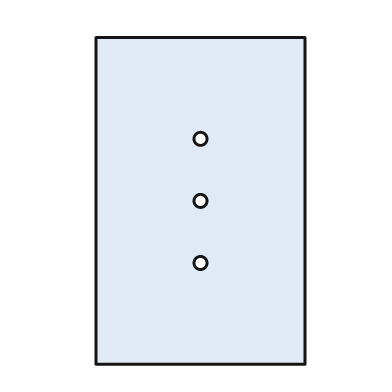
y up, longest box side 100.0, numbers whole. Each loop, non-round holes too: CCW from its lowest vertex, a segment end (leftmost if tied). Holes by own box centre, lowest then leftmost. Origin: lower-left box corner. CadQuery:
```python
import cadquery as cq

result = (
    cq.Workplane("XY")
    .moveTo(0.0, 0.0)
    .lineTo(64.0, 0.0)
    .lineTo(64.0, 100.0)
    .lineTo(0.0, 100.0)
    .close()
    .moveTo(32.0, 31.0)
    .circle(2.0)
    .moveTo(32.0, 50.0)
    .circle(2.0)
    .moveTo(32.0, 69.0)
    .circle(2.0)
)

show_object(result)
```